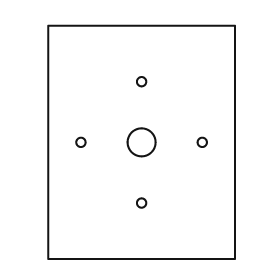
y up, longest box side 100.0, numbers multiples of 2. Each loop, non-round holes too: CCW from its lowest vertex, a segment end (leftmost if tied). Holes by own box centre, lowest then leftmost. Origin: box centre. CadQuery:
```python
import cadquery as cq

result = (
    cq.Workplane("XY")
    .moveTo(-40.0, -50.0)
    .lineTo(40.0, -50.0)
    .lineTo(40.0, 50.0)
    .lineTo(-40.0, 50.0)
    .close()
    .moveTo(0.0, -26.0)
    .circle(2.0)
    .moveTo(-26.0, 0.0)
    .circle(2.0)
    .moveTo(0.0, 0.0)
    .circle(6.0)
    .moveTo(26.0, 0.0)
    .circle(2.0)
    .moveTo(0.0, 26.0)
    .circle(2.0)
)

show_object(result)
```